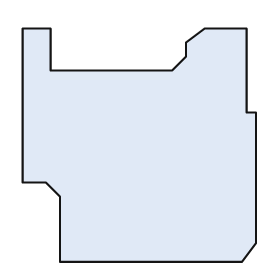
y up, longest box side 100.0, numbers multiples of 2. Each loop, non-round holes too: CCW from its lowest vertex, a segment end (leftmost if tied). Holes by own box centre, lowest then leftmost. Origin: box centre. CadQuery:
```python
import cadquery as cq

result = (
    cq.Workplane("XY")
    .moveTo(-34.0, -50.0)
    .lineTo(44.0, -50.0)
    .lineTo(50.0, -42.0)
    .lineTo(50.0, 14.0)
    .lineTo(46.0, 14.0)
    .lineTo(46.0, 50.0)
    .lineTo(28.0, 50.0)
    .lineTo(20.0, 44.0)
    .lineTo(20.0, 38.0)
    .lineTo(14.0, 32.0)
    .lineTo(-38.0, 32.0)
    .lineTo(-38.0, 50.0)
    .lineTo(-50.0, 50.0)
    .lineTo(-50.0, -16.0)
    .lineTo(-40.0, -16.0)
    .lineTo(-34.0, -22.0)
    .close()
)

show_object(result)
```